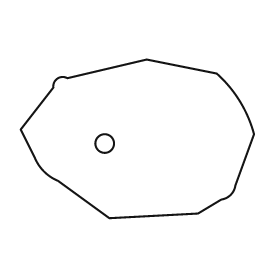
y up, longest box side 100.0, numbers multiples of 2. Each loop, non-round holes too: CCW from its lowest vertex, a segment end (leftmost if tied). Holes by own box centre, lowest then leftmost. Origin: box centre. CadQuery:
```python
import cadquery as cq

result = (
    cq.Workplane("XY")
    .moveTo(-12.0, -34.0)
    .lineTo(26.0, -32.0)
    .lineTo(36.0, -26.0)
    .threePointArc((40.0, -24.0), (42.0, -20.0))
    .lineTo(50.0, 2.0)
    .threePointArc((44.0, 16.0), (34.0, 28.0))
    .lineTo(4.0, 34.0)
    .lineTo(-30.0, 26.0)
    .threePointArc((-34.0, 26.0), (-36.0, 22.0))
    .lineTo(-50.0, 4.0)
    .lineTo(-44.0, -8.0)
    .threePointArc((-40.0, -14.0), (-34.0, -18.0))
    .close()
    .moveTo(-14.0, -2.0)
    .circle(4.0)
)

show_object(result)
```